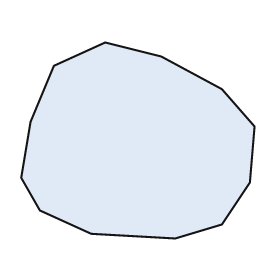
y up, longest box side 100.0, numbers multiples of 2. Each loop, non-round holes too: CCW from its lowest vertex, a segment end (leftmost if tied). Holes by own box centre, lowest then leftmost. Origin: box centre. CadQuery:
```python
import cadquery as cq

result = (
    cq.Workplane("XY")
    .moveTo(16.0, -42.0)
    .lineTo(36.0, -36.0)
    .lineTo(48.0, -18.0)
    .lineTo(50.0, 6.0)
    .lineTo(36.0, 22.0)
    .lineTo(10.0, 36.0)
    .lineTo(-14.0, 42.0)
    .lineTo(-36.0, 32.0)
    .lineTo(-46.0, 8.0)
    .lineTo(-50.0, -16.0)
    .lineTo(-42.0, -30.0)
    .lineTo(-20.0, -40.0)
    .close()
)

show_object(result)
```